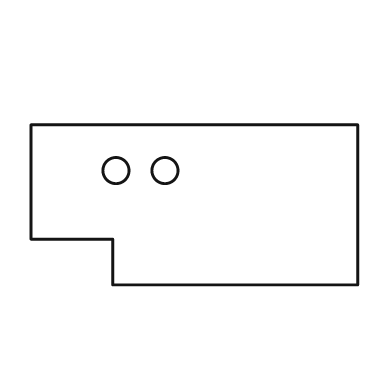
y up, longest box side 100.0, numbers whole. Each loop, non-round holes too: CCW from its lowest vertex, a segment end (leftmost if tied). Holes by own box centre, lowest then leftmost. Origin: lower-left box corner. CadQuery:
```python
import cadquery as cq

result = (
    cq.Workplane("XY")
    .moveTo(25.0, 0.0)
    .lineTo(100.0, 0.0)
    .lineTo(100.0, 49.0)
    .lineTo(0.0, 49.0)
    .lineTo(0.0, 14.0)
    .lineTo(25.0, 14.0)
    .close()
    .moveTo(26.0, 35.0)
    .circle(4.0)
    .moveTo(41.0, 35.0)
    .circle(4.0)
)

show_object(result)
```